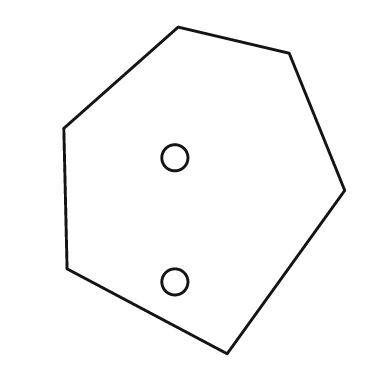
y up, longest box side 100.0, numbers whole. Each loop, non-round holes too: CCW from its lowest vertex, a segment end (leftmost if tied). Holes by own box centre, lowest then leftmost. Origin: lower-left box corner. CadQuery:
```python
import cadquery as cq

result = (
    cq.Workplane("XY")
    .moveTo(50.0, 0.0)
    .lineTo(86.0, 50.0)
    .lineTo(69.0, 92.0)
    .lineTo(35.0, 100.0)
    .lineTo(0.0, 69.0)
    .lineTo(1.0, 26.0)
    .close()
    .moveTo(34.0, 22.0)
    .circle(4.0)
    .moveTo(34.0, 60.0)
    .circle(4.0)
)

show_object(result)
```